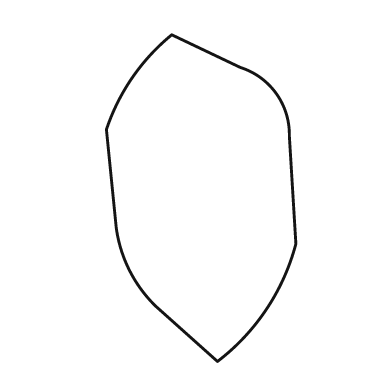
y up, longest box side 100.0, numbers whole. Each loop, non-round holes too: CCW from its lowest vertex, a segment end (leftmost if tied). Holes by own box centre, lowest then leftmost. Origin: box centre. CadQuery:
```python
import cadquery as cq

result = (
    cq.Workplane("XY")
    .moveTo(5.0, -50.0)
    .threePointArc((20.0, -34.0), (29.0, -14.0))
    .lineTo(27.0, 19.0)
    .threePointArc((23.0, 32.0), (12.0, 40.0))
    .lineTo(-9.0, 50.0)
    .threePointArc((-21.0, 37.0), (-29.0, 21.0))
    .lineTo(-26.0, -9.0)
    .threePointArc((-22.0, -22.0), (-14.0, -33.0))
    .close()
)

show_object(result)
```